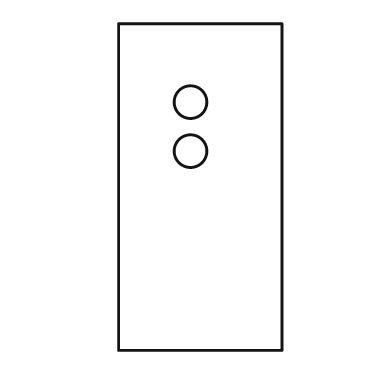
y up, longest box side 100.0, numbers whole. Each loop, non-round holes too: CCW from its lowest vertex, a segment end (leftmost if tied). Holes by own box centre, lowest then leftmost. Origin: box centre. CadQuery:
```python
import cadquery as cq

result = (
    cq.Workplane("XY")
    .moveTo(-25.0, -50.0)
    .lineTo(25.0, -50.0)
    .lineTo(25.0, 50.0)
    .lineTo(-25.0, 50.0)
    .close()
    .moveTo(-3.0, 11.0)
    .circle(5.0)
    .moveTo(-3.0, 26.0)
    .circle(5.0)
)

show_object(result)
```